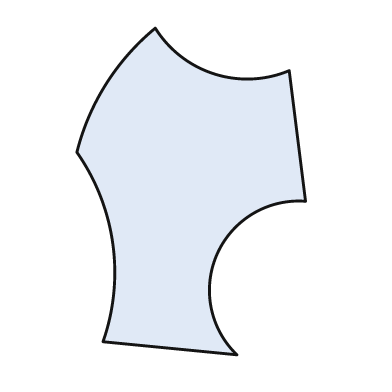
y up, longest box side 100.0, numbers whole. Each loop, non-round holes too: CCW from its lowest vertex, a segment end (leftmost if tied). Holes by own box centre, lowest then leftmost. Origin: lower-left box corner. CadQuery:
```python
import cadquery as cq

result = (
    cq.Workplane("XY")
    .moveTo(49.0, 0.0)
    .threePointArc((43.0, 31.0), (70.0, 47.0))
    .lineTo(65.0, 87.0)
    .threePointArc((42.0, 86.0), (24.0, 100.0))
    .threePointArc((9.0, 83.0), (0.0, 62.0))
    .threePointArc((11.0, 34.0), (8.0, 4.0))
    .close()
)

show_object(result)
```